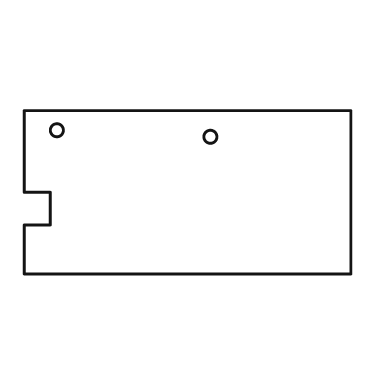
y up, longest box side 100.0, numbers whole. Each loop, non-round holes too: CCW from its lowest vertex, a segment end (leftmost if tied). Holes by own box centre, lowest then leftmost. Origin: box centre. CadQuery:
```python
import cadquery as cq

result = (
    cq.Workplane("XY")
    .moveTo(-50.0, -25.0)
    .lineTo(50.0, -25.0)
    .lineTo(50.0, 25.0)
    .lineTo(-50.0, 25.0)
    .lineTo(-50.0, 0.0)
    .lineTo(-42.0, 0.0)
    .lineTo(-42.0, -10.0)
    .lineTo(-50.0, -10.0)
    .close()
    .moveTo(7.0, 17.0)
    .circle(2.0)
    .moveTo(-40.0, 19.0)
    .circle(2.0)
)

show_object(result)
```